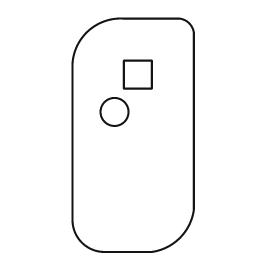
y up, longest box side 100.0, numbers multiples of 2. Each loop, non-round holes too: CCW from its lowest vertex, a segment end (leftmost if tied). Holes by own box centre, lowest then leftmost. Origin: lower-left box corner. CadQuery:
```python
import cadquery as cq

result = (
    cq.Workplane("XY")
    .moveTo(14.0, 0.0)
    .lineTo(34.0, 0.0)
    .threePointArc((46.0, 6.0), (52.0, 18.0))
    .lineTo(52.0, 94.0)
    .threePointArc((50.0, 98.0), (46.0, 100.0))
    .lineTo(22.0, 100.0)
    .threePointArc((6.0, 94.0), (0.0, 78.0))
    .lineTo(0.0, 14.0)
    .threePointArc((4.0, 4.0), (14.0, 0.0))
    .close()
    .moveTo(18.0, 60.0)
    .circle(6.0)
    .moveTo(22.0, 70.0)
    .lineTo(34.0, 70.0)
    .lineTo(34.0, 82.0)
    .lineTo(22.0, 82.0)
    .close()
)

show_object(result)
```